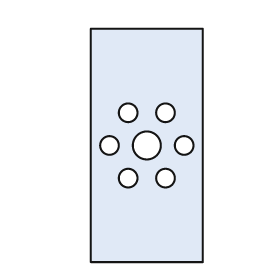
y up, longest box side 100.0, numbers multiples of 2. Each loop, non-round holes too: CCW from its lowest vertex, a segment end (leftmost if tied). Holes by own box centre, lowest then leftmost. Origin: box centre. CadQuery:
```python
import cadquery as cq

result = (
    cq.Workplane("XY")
    .moveTo(-24.0, -50.0)
    .lineTo(24.0, -50.0)
    .lineTo(24.0, 50.0)
    .lineTo(-24.0, 50.0)
    .close()
    .moveTo(-8.0, -14.0)
    .circle(4.0)
    .moveTo(8.0, -14.0)
    .circle(4.0)
    .moveTo(-16.0, 0.0)
    .circle(4.0)
    .moveTo(0.0, 0.0)
    .circle(6.0)
    .moveTo(16.0, 0.0)
    .circle(4.0)
    .moveTo(-8.0, 14.0)
    .circle(4.0)
    .moveTo(8.0, 14.0)
    .circle(4.0)
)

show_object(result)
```